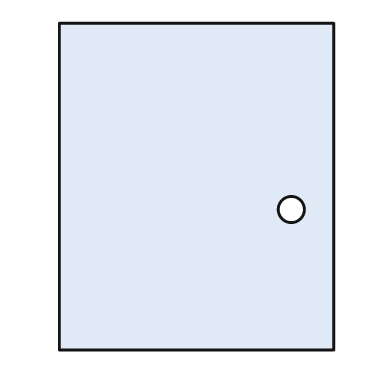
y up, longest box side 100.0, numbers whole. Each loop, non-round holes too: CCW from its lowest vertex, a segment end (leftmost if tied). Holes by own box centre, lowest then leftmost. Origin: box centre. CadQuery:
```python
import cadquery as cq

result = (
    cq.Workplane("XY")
    .moveTo(-42.0, -50.0)
    .lineTo(42.0, -50.0)
    .lineTo(42.0, 50.0)
    .lineTo(-42.0, 50.0)
    .close()
    .moveTo(29.0, -7.0)
    .circle(4.0)
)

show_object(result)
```